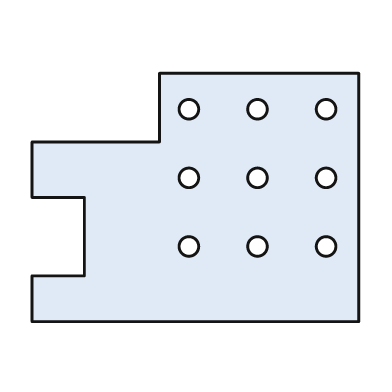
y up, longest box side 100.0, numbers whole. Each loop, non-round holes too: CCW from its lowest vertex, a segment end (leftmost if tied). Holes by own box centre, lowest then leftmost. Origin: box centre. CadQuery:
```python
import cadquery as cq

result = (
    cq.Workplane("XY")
    .moveTo(-50.0, -38.0)
    .lineTo(50.0, -38.0)
    .lineTo(50.0, 38.0)
    .lineTo(-11.0, 38.0)
    .lineTo(-11.0, 17.0)
    .lineTo(-50.0, 17.0)
    .lineTo(-50.0, 0.0)
    .lineTo(-34.0, 0.0)
    .lineTo(-34.0, -24.0)
    .lineTo(-50.0, -24.0)
    .close()
    .moveTo(-2.0, -15.0)
    .circle(3.0)
    .moveTo(19.0, -15.0)
    .circle(3.0)
    .moveTo(40.0, -15.0)
    .circle(3.0)
    .moveTo(-2.0, 6.0)
    .circle(3.0)
    .moveTo(19.0, 6.0)
    .circle(3.0)
    .moveTo(40.0, 6.0)
    .circle(3.0)
    .moveTo(-2.0, 27.0)
    .circle(3.0)
    .moveTo(19.0, 27.0)
    .circle(3.0)
    .moveTo(40.0, 27.0)
    .circle(3.0)
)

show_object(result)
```